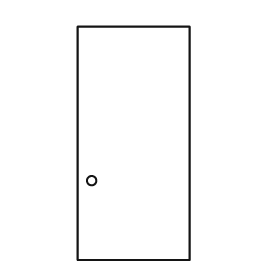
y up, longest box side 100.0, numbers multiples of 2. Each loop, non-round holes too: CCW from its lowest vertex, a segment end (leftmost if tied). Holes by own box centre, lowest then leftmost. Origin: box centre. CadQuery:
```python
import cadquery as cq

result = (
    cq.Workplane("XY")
    .moveTo(-24.0, -50.0)
    .lineTo(24.0, -50.0)
    .lineTo(24.0, 50.0)
    .lineTo(-24.0, 50.0)
    .close()
    .moveTo(-18.0, -16.0)
    .circle(2.0)
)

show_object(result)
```